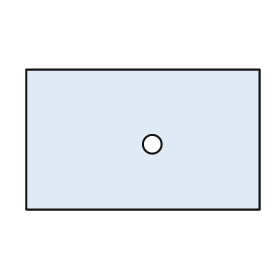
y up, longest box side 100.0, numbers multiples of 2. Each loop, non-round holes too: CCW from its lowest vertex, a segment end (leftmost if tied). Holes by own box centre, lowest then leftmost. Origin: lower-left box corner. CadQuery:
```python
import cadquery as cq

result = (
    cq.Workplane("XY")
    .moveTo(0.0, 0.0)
    .lineTo(100.0, 0.0)
    .lineTo(100.0, 60.0)
    .lineTo(0.0, 60.0)
    .close()
    .moveTo(54.0, 28.0)
    .circle(4.0)
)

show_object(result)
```